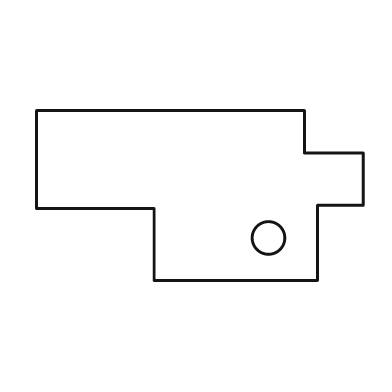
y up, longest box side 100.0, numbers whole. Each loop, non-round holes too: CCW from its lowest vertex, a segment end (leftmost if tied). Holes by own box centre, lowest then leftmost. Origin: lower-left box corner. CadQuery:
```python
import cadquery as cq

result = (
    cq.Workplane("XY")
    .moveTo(36.0, 0.0)
    .lineTo(86.0, 0.0)
    .lineTo(86.0, 23.0)
    .lineTo(100.0, 23.0)
    .lineTo(100.0, 39.0)
    .lineTo(82.0, 39.0)
    .lineTo(82.0, 52.0)
    .lineTo(0.0, 52.0)
    .lineTo(0.0, 22.0)
    .lineTo(36.0, 22.0)
    .close()
    .moveTo(71.0, 13.0)
    .circle(5.0)
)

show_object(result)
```